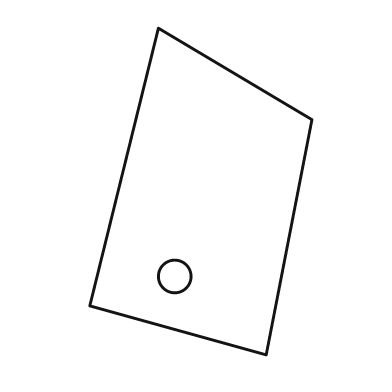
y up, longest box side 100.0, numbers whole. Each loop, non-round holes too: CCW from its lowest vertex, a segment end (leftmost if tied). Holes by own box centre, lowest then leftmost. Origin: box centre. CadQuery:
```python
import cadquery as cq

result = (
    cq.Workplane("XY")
    .moveTo(20.0, -50.0)
    .lineTo(34.0, 22.0)
    .lineTo(-13.0, 50.0)
    .lineTo(-34.0, -35.0)
    .close()
    .moveTo(-8.0, -26.0)
    .circle(5.0)
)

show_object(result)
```